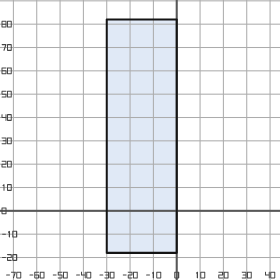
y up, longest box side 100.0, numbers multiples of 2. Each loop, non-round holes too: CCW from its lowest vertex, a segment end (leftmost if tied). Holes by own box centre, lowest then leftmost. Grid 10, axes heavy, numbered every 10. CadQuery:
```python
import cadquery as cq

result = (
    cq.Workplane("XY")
    .moveTo(-30.0, -18.0)
    .lineTo(0.0, -18.0)
    .lineTo(0.0, 82.0)
    .lineTo(-30.0, 82.0)
    .close()
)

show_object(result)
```